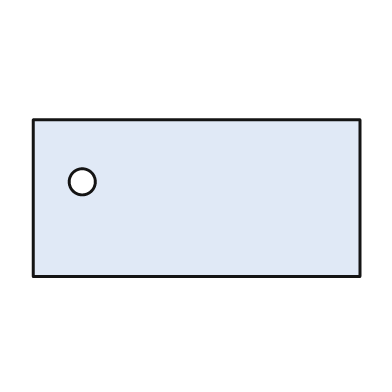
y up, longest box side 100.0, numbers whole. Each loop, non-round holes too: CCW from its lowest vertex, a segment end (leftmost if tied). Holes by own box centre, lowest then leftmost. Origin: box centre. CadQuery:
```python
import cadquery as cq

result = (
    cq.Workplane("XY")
    .moveTo(-50.0, -24.0)
    .lineTo(50.0, -24.0)
    .lineTo(50.0, 24.0)
    .lineTo(-50.0, 24.0)
    .close()
    .moveTo(-35.0, 5.0)
    .circle(4.0)
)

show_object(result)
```